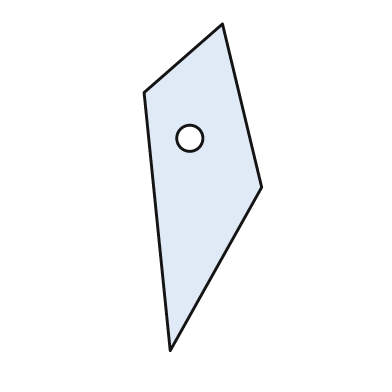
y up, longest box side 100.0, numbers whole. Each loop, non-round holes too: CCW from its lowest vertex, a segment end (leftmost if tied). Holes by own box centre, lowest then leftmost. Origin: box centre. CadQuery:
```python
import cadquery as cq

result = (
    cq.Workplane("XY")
    .moveTo(-10.0, -50.0)
    .lineTo(18.0, 0.0)
    .lineTo(6.0, 50.0)
    .lineTo(-18.0, 29.0)
    .close()
    .moveTo(-4.0, 15.0)
    .circle(4.0)
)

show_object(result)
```